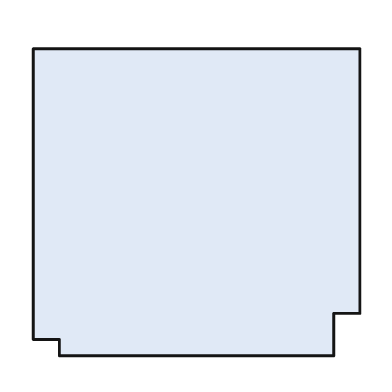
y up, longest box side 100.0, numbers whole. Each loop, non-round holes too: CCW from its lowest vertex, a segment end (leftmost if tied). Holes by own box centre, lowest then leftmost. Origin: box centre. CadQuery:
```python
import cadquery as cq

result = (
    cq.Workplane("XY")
    .moveTo(-42.0, -47.0)
    .lineTo(42.0, -47.0)
    .lineTo(42.0, -34.0)
    .lineTo(50.0, -34.0)
    .lineTo(50.0, 47.0)
    .lineTo(-50.0, 47.0)
    .lineTo(-50.0, -42.0)
    .lineTo(-42.0, -42.0)
    .close()
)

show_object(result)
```